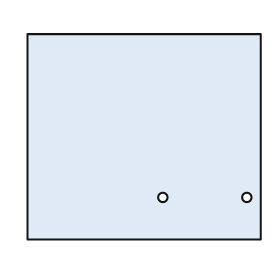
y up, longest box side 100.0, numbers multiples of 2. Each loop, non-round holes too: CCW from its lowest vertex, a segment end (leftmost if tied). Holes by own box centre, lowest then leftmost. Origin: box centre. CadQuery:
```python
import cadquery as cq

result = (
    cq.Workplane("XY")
    .moveTo(-50.0, -44.0)
    .lineTo(50.0, -44.0)
    .lineTo(50.0, 44.0)
    .lineTo(-50.0, 44.0)
    .close()
    .moveTo(8.0, -26.0)
    .circle(2.0)
    .moveTo(44.0, -26.0)
    .circle(2.0)
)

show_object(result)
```